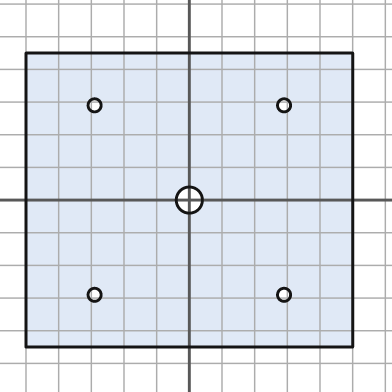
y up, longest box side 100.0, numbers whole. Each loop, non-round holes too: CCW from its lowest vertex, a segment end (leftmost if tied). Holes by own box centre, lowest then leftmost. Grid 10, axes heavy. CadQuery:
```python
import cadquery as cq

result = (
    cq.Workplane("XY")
    .moveTo(-50.0, -45.0)
    .lineTo(50.0, -45.0)
    .lineTo(50.0, 45.0)
    .lineTo(-50.0, 45.0)
    .close()
    .moveTo(-29.0, -29.0)
    .circle(2.0)
    .moveTo(29.0, -29.0)
    .circle(2.0)
    .moveTo(0.0, 0.0)
    .circle(4.0)
    .moveTo(-29.0, 29.0)
    .circle(2.0)
    .moveTo(29.0, 29.0)
    .circle(2.0)
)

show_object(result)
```